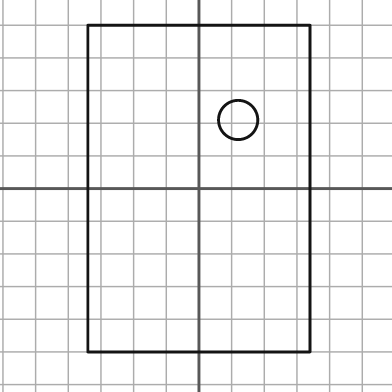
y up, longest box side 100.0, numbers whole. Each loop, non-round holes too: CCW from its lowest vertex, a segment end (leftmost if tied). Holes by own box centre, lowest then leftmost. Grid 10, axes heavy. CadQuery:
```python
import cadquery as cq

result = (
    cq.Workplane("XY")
    .moveTo(-34.0, -50.0)
    .lineTo(34.0, -50.0)
    .lineTo(34.0, 50.0)
    .lineTo(-34.0, 50.0)
    .close()
    .moveTo(12.0, 21.0)
    .circle(6.0)
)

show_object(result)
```